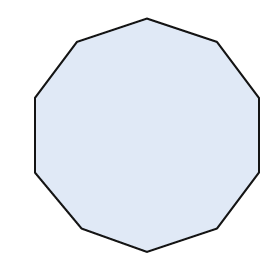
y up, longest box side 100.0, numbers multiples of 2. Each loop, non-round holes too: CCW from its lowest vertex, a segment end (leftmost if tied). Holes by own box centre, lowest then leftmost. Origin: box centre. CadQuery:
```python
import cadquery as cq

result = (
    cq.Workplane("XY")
    .moveTo(0.0, -50.0)
    .lineTo(30.0, -40.0)
    .lineTo(48.0, -16.0)
    .lineTo(48.0, 16.0)
    .lineTo(30.0, 40.0)
    .lineTo(0.0, 50.0)
    .lineTo(-30.0, 40.0)
    .lineTo(-48.0, 16.0)
    .lineTo(-48.0, -16.0)
    .lineTo(-28.0, -40.0)
    .close()
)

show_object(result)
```